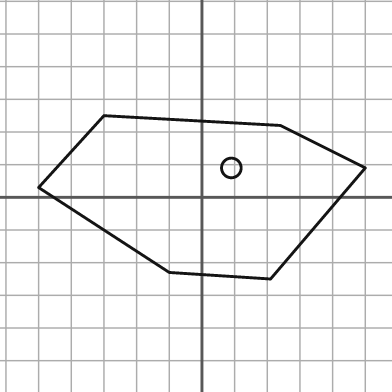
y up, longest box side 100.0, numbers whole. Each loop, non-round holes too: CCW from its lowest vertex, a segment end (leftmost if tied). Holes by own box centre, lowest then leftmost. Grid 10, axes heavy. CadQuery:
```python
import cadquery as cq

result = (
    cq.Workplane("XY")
    .moveTo(21.0, -25.0)
    .lineTo(50.0, 9.0)
    .lineTo(24.0, 22.0)
    .lineTo(-30.0, 25.0)
    .lineTo(-50.0, 3.0)
    .lineTo(-10.0, -23.0)
    .close()
    .moveTo(9.0, 9.0)
    .circle(3.0)
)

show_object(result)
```